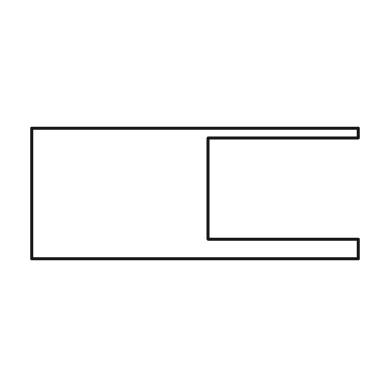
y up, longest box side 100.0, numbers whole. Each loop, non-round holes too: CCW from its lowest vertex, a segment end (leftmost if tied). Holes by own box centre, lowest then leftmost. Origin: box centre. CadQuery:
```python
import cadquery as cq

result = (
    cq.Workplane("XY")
    .moveTo(-50.0, -20.0)
    .lineTo(50.0, -20.0)
    .lineTo(50.0, -14.0)
    .lineTo(4.0, -14.0)
    .lineTo(4.0, 17.0)
    .lineTo(50.0, 17.0)
    .lineTo(50.0, 20.0)
    .lineTo(-50.0, 20.0)
    .close()
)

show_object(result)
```